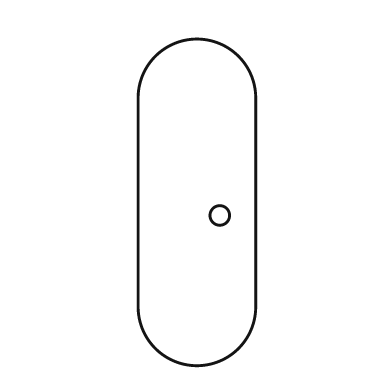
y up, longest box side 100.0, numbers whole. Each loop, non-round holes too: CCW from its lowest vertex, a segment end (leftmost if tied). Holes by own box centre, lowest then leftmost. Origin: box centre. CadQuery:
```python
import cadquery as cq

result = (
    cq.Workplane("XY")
    .moveTo(-18.0, -32.0)
    .threePointArc((0.0, -50.0), (18.0, -32.0))
    .lineTo(18.0, 32.0)
    .threePointArc((0.0, 50.0), (-18.0, 32.0))
    .close()
    .moveTo(7.0, -4.0)
    .circle(3.0)
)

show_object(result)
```